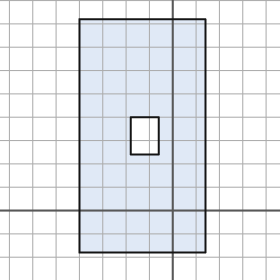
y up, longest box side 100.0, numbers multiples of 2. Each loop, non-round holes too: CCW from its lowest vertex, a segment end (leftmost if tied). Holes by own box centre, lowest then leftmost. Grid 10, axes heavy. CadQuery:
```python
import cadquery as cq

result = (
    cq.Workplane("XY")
    .moveTo(-40.0, -18.0)
    .lineTo(14.0, -18.0)
    .lineTo(14.0, 82.0)
    .lineTo(-40.0, 82.0)
    .close()
    .moveTo(-18.0, 24.0)
    .lineTo(-6.0, 24.0)
    .lineTo(-6.0, 40.0)
    .lineTo(-18.0, 40.0)
    .close()
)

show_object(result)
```